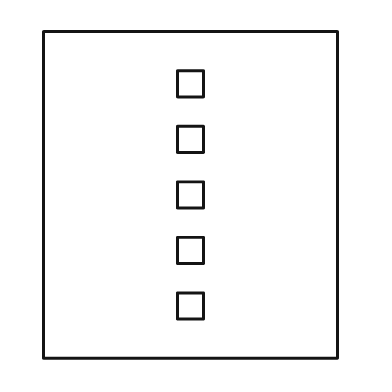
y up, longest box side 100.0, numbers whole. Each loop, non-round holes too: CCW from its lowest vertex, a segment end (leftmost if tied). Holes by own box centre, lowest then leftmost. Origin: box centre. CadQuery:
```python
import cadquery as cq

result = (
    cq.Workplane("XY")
    .moveTo(-45.0, -50.0)
    .lineTo(45.0, -50.0)
    .lineTo(45.0, 50.0)
    .lineTo(-45.0, 50.0)
    .close()
    .moveTo(-4.0, -38.0)
    .lineTo(4.0, -38.0)
    .lineTo(4.0, -30.0)
    .lineTo(-4.0, -30.0)
    .close()
    .moveTo(-4.0, -21.0)
    .lineTo(4.0, -21.0)
    .lineTo(4.0, -13.0)
    .lineTo(-4.0, -13.0)
    .close()
    .moveTo(-4.0, -4.0)
    .lineTo(4.0, -4.0)
    .lineTo(4.0, 4.0)
    .lineTo(-4.0, 4.0)
    .close()
    .moveTo(-4.0, 13.0)
    .lineTo(4.0, 13.0)
    .lineTo(4.0, 21.0)
    .lineTo(-4.0, 21.0)
    .close()
    .moveTo(-4.0, 30.0)
    .lineTo(4.0, 30.0)
    .lineTo(4.0, 38.0)
    .lineTo(-4.0, 38.0)
    .close()
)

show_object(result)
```